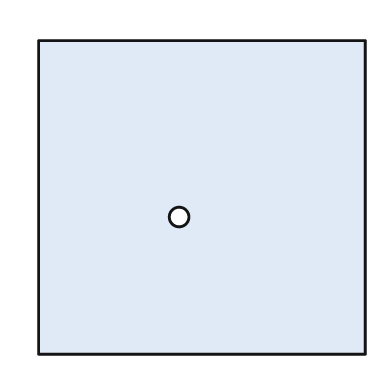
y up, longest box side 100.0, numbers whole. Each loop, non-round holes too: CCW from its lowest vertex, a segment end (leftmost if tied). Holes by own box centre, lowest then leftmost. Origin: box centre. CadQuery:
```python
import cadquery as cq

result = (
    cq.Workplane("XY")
    .moveTo(-50.0, -48.0)
    .lineTo(50.0, -48.0)
    .lineTo(50.0, 48.0)
    .lineTo(-50.0, 48.0)
    .close()
    .moveTo(-7.0, -6.0)
    .circle(3.0)
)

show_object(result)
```